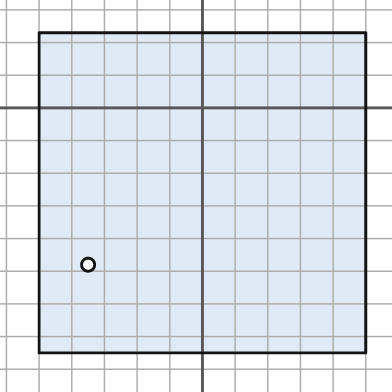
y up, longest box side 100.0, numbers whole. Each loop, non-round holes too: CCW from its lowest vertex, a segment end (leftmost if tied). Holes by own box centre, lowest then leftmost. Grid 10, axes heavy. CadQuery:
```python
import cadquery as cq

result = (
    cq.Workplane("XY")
    .moveTo(-50.0, -75.0)
    .lineTo(50.0, -75.0)
    .lineTo(50.0, 23.0)
    .lineTo(-50.0, 23.0)
    .close()
    .moveTo(-35.0, -48.0)
    .circle(2.0)
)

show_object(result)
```